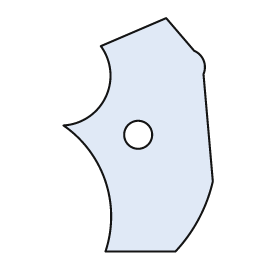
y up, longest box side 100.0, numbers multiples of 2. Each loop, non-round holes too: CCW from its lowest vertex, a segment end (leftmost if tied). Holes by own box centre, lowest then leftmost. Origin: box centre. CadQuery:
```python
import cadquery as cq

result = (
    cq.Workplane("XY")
    .moveTo(-14.0, -50.0)
    .lineTo(16.0, -50.0)
    .threePointArc((26.0, -36.0), (32.0, -20.0))
    .lineTo(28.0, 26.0)
    .threePointArc((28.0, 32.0), (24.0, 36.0))
    .lineTo(12.0, 50.0)
    .lineTo(-16.0, 38.0)
    .threePointArc((-14.0, 16.0), (-32.0, 4.0))
    .threePointArc((-14.0, -20.0), (-14.0, -50.0))
    .close()
    .moveTo(0.0, 0.0)
    .circle(6.0)
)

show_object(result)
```